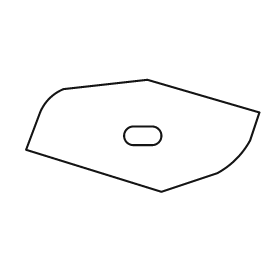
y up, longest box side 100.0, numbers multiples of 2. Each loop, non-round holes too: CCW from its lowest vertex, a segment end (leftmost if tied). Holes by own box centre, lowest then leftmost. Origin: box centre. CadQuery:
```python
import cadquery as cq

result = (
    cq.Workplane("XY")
    .moveTo(8.0, -24.0)
    .lineTo(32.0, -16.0)
    .threePointArc((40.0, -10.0), (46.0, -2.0))
    .lineTo(50.0, 10.0)
    .lineTo(2.0, 24.0)
    .lineTo(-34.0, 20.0)
    .threePointArc((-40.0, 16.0), (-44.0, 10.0))
    .lineTo(-50.0, -6.0)
    .close()
    .moveTo(-4.0, -4.0)
    .lineTo(4.0, -4.0)
    .threePointArc((8.0, 0.0), (4.0, 4.0))
    .lineTo(-4.0, 4.0)
    .threePointArc((-8.0, 0.0), (-4.0, -4.0))
    .close()
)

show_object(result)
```